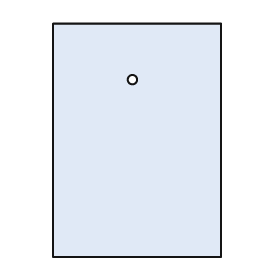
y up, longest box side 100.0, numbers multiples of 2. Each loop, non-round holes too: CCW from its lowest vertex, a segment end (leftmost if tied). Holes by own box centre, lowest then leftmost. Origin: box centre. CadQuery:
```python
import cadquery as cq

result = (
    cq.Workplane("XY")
    .moveTo(-36.0, -50.0)
    .lineTo(36.0, -50.0)
    .lineTo(36.0, 50.0)
    .lineTo(-36.0, 50.0)
    .close()
    .moveTo(-2.0, 26.0)
    .circle(2.0)
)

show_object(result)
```